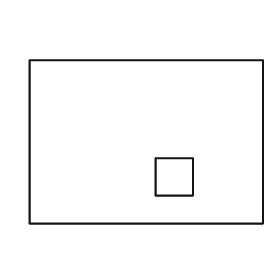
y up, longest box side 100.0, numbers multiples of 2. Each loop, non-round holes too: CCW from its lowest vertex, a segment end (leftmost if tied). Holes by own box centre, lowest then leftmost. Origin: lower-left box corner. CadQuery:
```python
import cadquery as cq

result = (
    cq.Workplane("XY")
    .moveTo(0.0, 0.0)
    .lineTo(100.0, 0.0)
    .lineTo(100.0, 70.0)
    .lineTo(0.0, 70.0)
    .close()
    .moveTo(54.0, 12.0)
    .lineTo(70.0, 12.0)
    .lineTo(70.0, 28.0)
    .lineTo(54.0, 28.0)
    .close()
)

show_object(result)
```